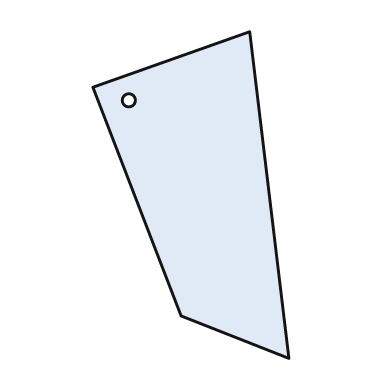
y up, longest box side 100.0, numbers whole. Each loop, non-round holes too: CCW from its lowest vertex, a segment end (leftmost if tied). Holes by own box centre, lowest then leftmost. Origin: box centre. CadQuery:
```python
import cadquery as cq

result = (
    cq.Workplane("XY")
    .moveTo(30.0, -50.0)
    .lineTo(18.0, 50.0)
    .lineTo(-30.0, 33.0)
    .lineTo(-3.0, -37.0)
    .close()
    .moveTo(-19.0, 29.0)
    .circle(2.0)
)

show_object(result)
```